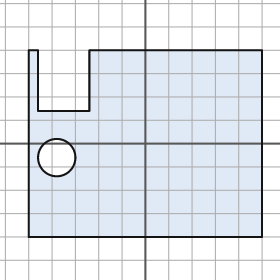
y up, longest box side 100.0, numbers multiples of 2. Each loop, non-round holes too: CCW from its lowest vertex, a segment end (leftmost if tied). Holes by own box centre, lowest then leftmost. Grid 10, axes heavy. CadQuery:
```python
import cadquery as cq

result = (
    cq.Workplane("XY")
    .moveTo(-50.0, -40.0)
    .lineTo(50.0, -40.0)
    .lineTo(50.0, 40.0)
    .lineTo(-24.0, 40.0)
    .lineTo(-24.0, 14.0)
    .lineTo(-46.0, 14.0)
    .lineTo(-46.0, 40.0)
    .lineTo(-50.0, 40.0)
    .close()
    .moveTo(-38.0, -6.0)
    .circle(8.0)
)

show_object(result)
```